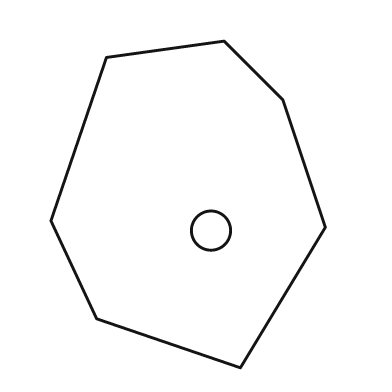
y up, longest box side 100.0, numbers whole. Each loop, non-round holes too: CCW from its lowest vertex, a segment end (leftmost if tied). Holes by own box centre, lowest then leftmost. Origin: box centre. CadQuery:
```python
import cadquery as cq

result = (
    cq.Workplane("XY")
    .moveTo(16.0, -50.0)
    .lineTo(42.0, -7.0)
    .lineTo(29.0, 32.0)
    .lineTo(11.0, 50.0)
    .lineTo(-25.0, 45.0)
    .lineTo(-42.0, -5.0)
    .lineTo(-28.0, -35.0)
    .close()
    .moveTo(7.0, -8.0)
    .circle(6.0)
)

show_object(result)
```